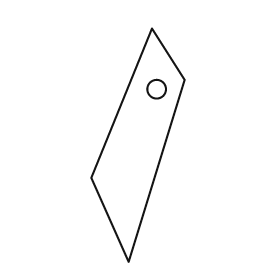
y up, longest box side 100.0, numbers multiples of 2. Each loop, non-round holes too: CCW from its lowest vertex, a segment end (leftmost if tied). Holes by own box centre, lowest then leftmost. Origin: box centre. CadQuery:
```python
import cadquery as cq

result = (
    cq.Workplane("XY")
    .moveTo(-4.0, -50.0)
    .lineTo(20.0, 28.0)
    .lineTo(6.0, 50.0)
    .lineTo(-20.0, -14.0)
    .close()
    .moveTo(8.0, 24.0)
    .circle(4.0)
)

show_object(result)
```